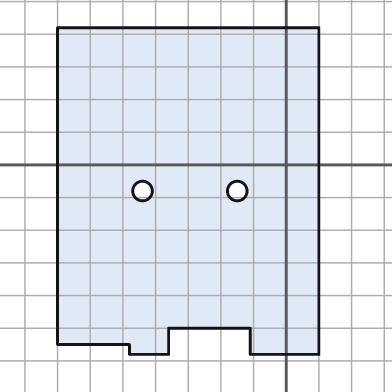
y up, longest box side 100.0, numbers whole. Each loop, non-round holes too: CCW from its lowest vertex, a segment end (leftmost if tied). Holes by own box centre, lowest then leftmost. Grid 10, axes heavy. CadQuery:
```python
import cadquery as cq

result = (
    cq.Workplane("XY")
    .moveTo(-48.0, -58.0)
    .lineTo(-36.0, -58.0)
    .lineTo(-36.0, -50.0)
    .lineTo(-11.0, -50.0)
    .lineTo(-11.0, -58.0)
    .lineTo(10.0, -58.0)
    .lineTo(10.0, 42.0)
    .lineTo(-70.0, 42.0)
    .lineTo(-70.0, -55.0)
    .lineTo(-48.0, -55.0)
    .close()
    .moveTo(-44.0, -8.0)
    .circle(3.0)
    .moveTo(-15.0, -8.0)
    .circle(3.0)
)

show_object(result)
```